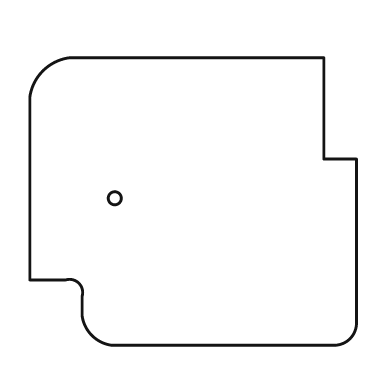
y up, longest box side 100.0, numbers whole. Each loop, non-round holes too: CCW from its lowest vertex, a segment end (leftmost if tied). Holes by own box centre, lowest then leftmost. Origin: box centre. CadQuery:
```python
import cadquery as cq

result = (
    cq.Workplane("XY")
    .moveTo(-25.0, -44.0)
    .lineTo(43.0, -44.0)
    .threePointArc((48.0, -42.0), (50.0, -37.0))
    .lineTo(50.0, 13.0)
    .lineTo(40.0, 13.0)
    .lineTo(40.0, 44.0)
    .lineTo(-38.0, 44.0)
    .threePointArc((-46.0, 40.0), (-50.0, 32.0))
    .lineTo(-50.0, -24.0)
    .lineTo(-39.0, -24.0)
    .threePointArc((-35.0, -25.0), (-34.0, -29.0))
    .lineTo(-34.0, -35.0)
    .threePointArc((-31.0, -41.0), (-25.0, -44.0))
    .close()
    .moveTo(-24.0, 1.0)
    .circle(2.0)
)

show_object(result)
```